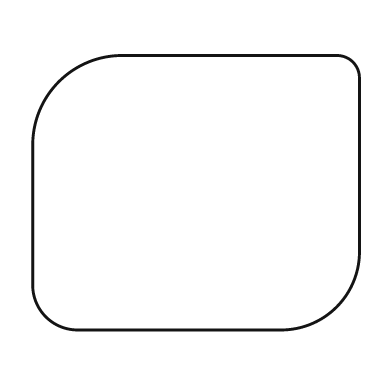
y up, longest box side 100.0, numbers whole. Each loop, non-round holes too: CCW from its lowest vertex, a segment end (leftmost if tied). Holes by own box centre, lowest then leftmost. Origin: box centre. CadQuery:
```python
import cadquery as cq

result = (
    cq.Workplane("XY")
    .moveTo(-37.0, -42.0)
    .lineTo(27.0, -42.0)
    .threePointArc((43.0, -35.0), (50.0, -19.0))
    .lineTo(50.0, 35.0)
    .threePointArc((48.0, 40.0), (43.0, 42.0))
    .lineTo(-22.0, 42.0)
    .threePointArc((-42.0, 34.0), (-50.0, 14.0))
    .lineTo(-50.0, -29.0)
    .threePointArc((-46.0, -38.0), (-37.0, -42.0))
    .close()
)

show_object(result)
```